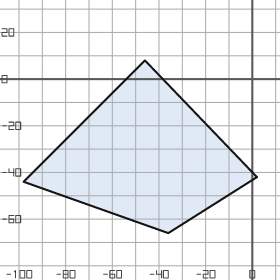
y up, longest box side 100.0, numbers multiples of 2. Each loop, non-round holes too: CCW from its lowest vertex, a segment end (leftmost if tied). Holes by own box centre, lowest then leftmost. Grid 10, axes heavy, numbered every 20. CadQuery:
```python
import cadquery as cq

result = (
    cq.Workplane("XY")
    .moveTo(-36.0, -66.0)
    .lineTo(2.0, -42.0)
    .lineTo(-46.0, 8.0)
    .lineTo(-98.0, -44.0)
    .close()
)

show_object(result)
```